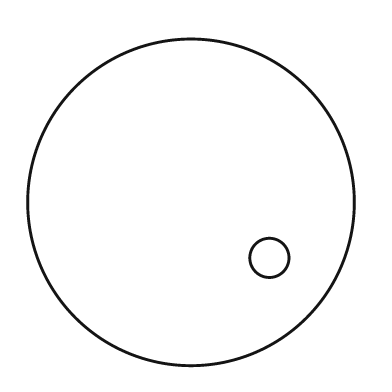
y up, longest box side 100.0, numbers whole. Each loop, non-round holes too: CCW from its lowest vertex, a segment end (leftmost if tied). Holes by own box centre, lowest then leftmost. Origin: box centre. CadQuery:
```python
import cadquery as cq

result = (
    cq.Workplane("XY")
    .moveTo(0.0, 0.0)
    .circle(50.0)
    .moveTo(24.0, -17.0)
    .circle(6.0)
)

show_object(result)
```